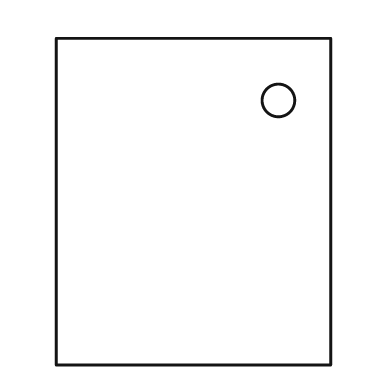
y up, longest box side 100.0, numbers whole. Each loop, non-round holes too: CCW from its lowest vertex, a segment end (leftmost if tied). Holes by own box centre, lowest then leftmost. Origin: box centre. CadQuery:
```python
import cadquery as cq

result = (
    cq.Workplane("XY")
    .moveTo(-42.0, -50.0)
    .lineTo(42.0, -50.0)
    .lineTo(42.0, 50.0)
    .lineTo(-42.0, 50.0)
    .close()
    .moveTo(26.0, 31.0)
    .circle(5.0)
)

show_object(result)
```